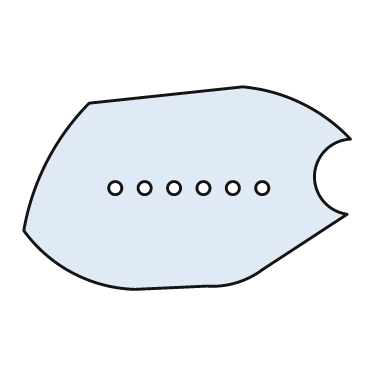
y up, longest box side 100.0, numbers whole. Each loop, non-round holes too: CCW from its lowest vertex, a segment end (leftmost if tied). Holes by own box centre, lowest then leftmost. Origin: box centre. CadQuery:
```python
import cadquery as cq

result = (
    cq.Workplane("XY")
    .moveTo(-16.0, -31.0)
    .lineTo(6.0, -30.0)
    .threePointArc((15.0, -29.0), (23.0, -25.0))
    .lineTo(49.0, -8.0)
    .threePointArc((39.0, 4.0), (50.0, 15.0))
    .threePointArc((35.0, 26.0), (17.0, 31.0))
    .lineTo(-30.0, 26.0)
    .threePointArc((-43.0, 8.0), (-50.0, -13.0))
    .threePointArc((-35.0, -26.0), (-16.0, -31.0))
    .close()
    .moveTo(-22.0, 0.0)
    .circle(2.0)
    .moveTo(-13.0, 0.0)
    .circle(2.0)
    .moveTo(-4.0, 0.0)
    .circle(2.0)
    .moveTo(5.0, 0.0)
    .circle(2.0)
    .moveTo(14.0, 0.0)
    .circle(2.0)
    .moveTo(23.0, 0.0)
    .circle(2.0)
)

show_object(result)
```